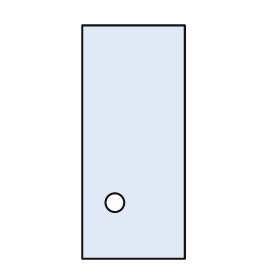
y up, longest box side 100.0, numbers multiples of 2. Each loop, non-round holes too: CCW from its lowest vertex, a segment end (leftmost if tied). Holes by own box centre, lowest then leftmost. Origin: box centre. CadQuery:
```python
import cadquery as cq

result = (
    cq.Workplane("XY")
    .moveTo(-22.0, -50.0)
    .lineTo(22.0, -50.0)
    .lineTo(22.0, 50.0)
    .lineTo(-22.0, 50.0)
    .close()
    .moveTo(-8.0, -26.0)
    .circle(4.0)
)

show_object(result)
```